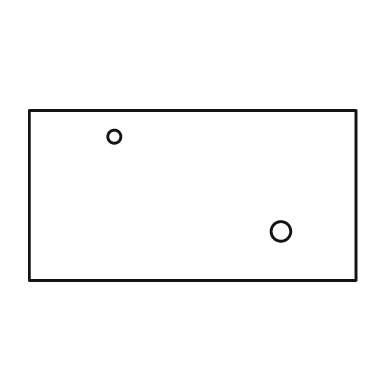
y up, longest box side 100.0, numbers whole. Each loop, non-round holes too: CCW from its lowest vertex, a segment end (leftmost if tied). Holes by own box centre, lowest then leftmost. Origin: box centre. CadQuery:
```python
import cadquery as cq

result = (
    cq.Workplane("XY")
    .moveTo(-50.0, -26.0)
    .lineTo(50.0, -26.0)
    .lineTo(50.0, 26.0)
    .lineTo(-50.0, 26.0)
    .close()
    .moveTo(27.0, -11.0)
    .circle(3.0)
    .moveTo(-24.0, 18.0)
    .circle(2.0)
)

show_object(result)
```